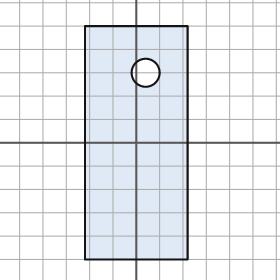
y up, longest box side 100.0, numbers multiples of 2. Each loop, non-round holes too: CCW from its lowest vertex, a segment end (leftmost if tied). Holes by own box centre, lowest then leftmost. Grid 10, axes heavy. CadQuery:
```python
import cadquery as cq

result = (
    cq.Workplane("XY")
    .moveTo(-22.0, -50.0)
    .lineTo(22.0, -50.0)
    .lineTo(22.0, 50.0)
    .lineTo(-22.0, 50.0)
    .close()
    .moveTo(4.0, 30.0)
    .circle(6.0)
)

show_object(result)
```